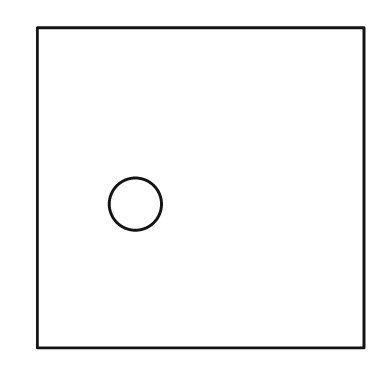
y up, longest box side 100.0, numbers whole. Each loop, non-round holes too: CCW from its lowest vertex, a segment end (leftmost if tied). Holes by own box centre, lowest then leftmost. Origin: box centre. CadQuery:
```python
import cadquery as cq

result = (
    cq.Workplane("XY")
    .moveTo(-50.0, -49.0)
    .lineTo(50.0, -49.0)
    .lineTo(50.0, 49.0)
    .lineTo(-50.0, 49.0)
    .close()
    .moveTo(-20.0, -5.0)
    .circle(8.0)
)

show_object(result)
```